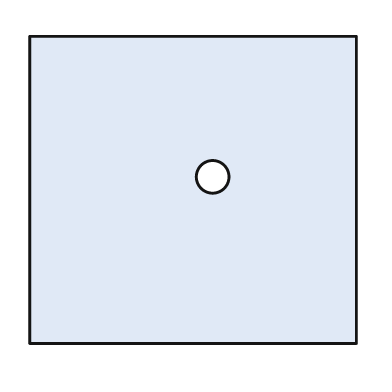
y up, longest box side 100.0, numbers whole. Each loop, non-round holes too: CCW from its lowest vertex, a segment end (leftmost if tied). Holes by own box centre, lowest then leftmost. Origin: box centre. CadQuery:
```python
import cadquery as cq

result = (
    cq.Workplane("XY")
    .moveTo(-50.0, -47.0)
    .lineTo(50.0, -47.0)
    .lineTo(50.0, 47.0)
    .lineTo(-50.0, 47.0)
    .close()
    .moveTo(6.0, 4.0)
    .circle(5.0)
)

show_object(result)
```